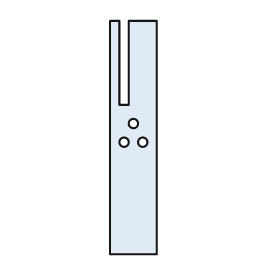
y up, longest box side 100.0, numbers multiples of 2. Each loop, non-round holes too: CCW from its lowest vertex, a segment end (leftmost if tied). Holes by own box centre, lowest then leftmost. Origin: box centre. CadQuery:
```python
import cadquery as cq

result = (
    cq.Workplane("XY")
    .moveTo(-10.0, -50.0)
    .lineTo(10.0, -50.0)
    .lineTo(10.0, 50.0)
    .lineTo(-2.0, 50.0)
    .lineTo(-2.0, 14.0)
    .lineTo(-6.0, 14.0)
    .lineTo(-6.0, 50.0)
    .lineTo(-10.0, 50.0)
    .close()
    .moveTo(-4.0, -2.0)
    .circle(2.0)
    .moveTo(4.0, -2.0)
    .circle(2.0)
    .moveTo(0.0, 6.0)
    .circle(2.0)
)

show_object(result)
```